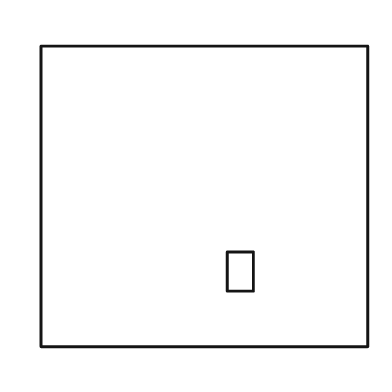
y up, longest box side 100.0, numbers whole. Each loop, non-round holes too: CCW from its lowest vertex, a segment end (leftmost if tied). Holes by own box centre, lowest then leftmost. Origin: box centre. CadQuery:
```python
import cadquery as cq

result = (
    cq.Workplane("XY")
    .moveTo(-50.0, -46.0)
    .lineTo(50.0, -46.0)
    .lineTo(50.0, 46.0)
    .lineTo(-50.0, 46.0)
    .close()
    .moveTo(7.0, -29.0)
    .lineTo(15.0, -29.0)
    .lineTo(15.0, -17.0)
    .lineTo(7.0, -17.0)
    .close()
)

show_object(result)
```